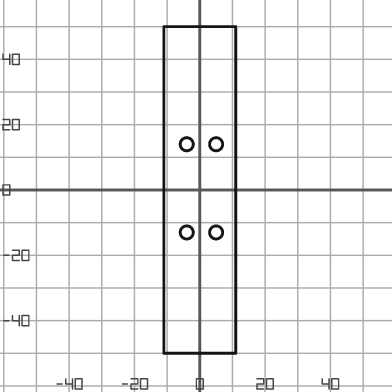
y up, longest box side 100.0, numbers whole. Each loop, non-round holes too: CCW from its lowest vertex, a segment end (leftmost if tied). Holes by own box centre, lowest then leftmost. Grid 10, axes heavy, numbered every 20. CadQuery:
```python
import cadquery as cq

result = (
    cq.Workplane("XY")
    .moveTo(-11.0, -50.0)
    .lineTo(11.0, -50.0)
    .lineTo(11.0, 50.0)
    .lineTo(-11.0, 50.0)
    .close()
    .moveTo(-4.0, -13.0)
    .circle(2.0)
    .moveTo(5.0, -13.0)
    .circle(2.0)
    .moveTo(-4.0, 14.0)
    .circle(2.0)
    .moveTo(5.0, 14.0)
    .circle(2.0)
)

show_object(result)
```